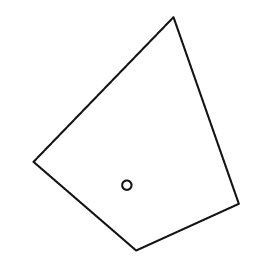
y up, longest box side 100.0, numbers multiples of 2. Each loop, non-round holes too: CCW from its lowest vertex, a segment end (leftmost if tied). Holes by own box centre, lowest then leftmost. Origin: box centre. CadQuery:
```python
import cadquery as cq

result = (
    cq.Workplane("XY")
    .moveTo(0.0, -50.0)
    .lineTo(44.0, -30.0)
    .lineTo(16.0, 50.0)
    .lineTo(-44.0, -12.0)
    .close()
    .moveTo(-4.0, -22.0)
    .circle(2.0)
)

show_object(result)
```